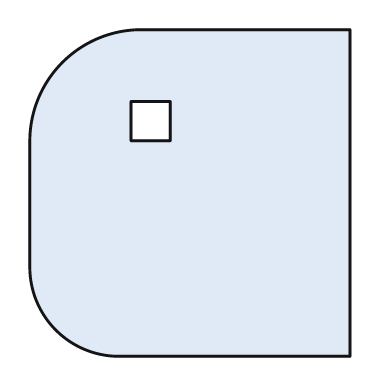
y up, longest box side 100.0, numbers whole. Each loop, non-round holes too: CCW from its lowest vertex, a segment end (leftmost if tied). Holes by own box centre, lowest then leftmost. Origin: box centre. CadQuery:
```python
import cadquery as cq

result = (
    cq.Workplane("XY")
    .moveTo(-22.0, -50.0)
    .lineTo(49.0, -50.0)
    .lineTo(49.0, 50.0)
    .lineTo(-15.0, 50.0)
    .threePointArc((-39.0, 40.0), (-49.0, 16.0))
    .lineTo(-49.0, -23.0)
    .threePointArc((-41.0, -42.0), (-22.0, -50.0))
    .close()
    .moveTo(-18.0, 16.0)
    .lineTo(-6.0, 16.0)
    .lineTo(-6.0, 28.0)
    .lineTo(-18.0, 28.0)
    .close()
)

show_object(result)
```